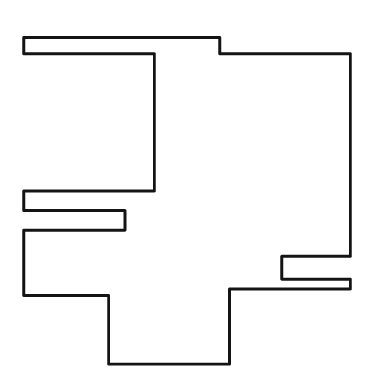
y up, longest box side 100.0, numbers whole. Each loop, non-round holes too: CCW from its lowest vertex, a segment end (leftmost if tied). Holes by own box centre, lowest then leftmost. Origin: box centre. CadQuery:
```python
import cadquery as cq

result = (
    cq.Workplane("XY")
    .moveTo(-24.0, -50.0)
    .lineTo(13.0, -50.0)
    .lineTo(13.0, -27.0)
    .lineTo(50.0, -27.0)
    .lineTo(50.0, -24.0)
    .lineTo(29.0, -24.0)
    .lineTo(29.0, -17.0)
    .lineTo(50.0, -17.0)
    .lineTo(50.0, 45.0)
    .lineTo(10.0, 45.0)
    .lineTo(10.0, 50.0)
    .lineTo(-50.0, 50.0)
    .lineTo(-50.0, 45.0)
    .lineTo(-10.0, 45.0)
    .lineTo(-10.0, 3.0)
    .lineTo(-50.0, 3.0)
    .lineTo(-50.0, -3.0)
    .lineTo(-19.0, -3.0)
    .lineTo(-19.0, -9.0)
    .lineTo(-50.0, -9.0)
    .lineTo(-50.0, -29.0)
    .lineTo(-24.0, -29.0)
    .close()
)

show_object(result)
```